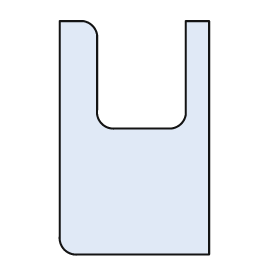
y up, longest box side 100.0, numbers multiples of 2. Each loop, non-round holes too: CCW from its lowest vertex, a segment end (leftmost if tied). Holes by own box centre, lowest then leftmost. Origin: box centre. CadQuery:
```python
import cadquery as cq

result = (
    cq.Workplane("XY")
    .moveTo(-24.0, -50.0)
    .lineTo(32.0, -50.0)
    .lineTo(32.0, 50.0)
    .lineTo(22.0, 50.0)
    .lineTo(22.0, 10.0)
    .threePointArc((20.0, 6.0), (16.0, 4.0))
    .lineTo(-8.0, 4.0)
    .threePointArc((-14.0, 6.0), (-16.0, 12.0))
    .lineTo(-16.0, 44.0)
    .threePointArc((-18.0, 48.0), (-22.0, 50.0))
    .lineTo(-32.0, 50.0)
    .lineTo(-32.0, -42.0)
    .threePointArc((-30.0, -48.0), (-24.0, -50.0))
    .close()
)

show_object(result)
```